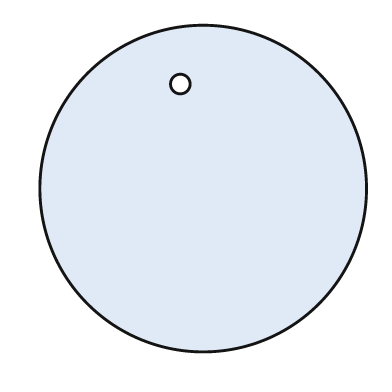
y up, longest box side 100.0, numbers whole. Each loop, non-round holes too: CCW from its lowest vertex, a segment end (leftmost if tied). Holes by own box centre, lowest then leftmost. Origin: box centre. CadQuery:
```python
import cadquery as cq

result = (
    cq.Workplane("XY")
    .moveTo(0.0, 0.0)
    .circle(50.0)
    .moveTo(-7.0, 32.0)
    .circle(3.0)
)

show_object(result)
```